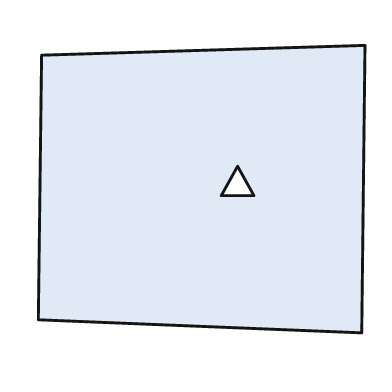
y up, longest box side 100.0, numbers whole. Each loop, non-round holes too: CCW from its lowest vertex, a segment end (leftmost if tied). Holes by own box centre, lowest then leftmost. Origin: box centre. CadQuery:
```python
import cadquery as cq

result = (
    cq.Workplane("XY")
    .moveTo(49.0, -44.0)
    .lineTo(50.0, 44.0)
    .lineTo(-49.0, 41.0)
    .lineTo(-50.0, -40.0)
    .close()
    .moveTo(6.0, -2.0)
    .lineTo(16.0, -2.0)
    .lineTo(11.0, 7.0)
    .close()
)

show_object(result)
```